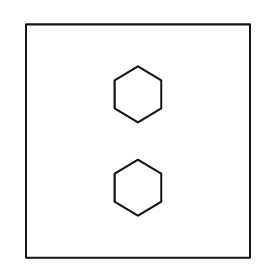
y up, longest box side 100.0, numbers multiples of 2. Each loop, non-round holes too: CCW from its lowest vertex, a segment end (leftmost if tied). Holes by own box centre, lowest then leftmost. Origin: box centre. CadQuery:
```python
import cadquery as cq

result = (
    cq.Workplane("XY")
    .moveTo(-48.0, -50.0)
    .lineTo(48.0, -50.0)
    .lineTo(48.0, 50.0)
    .lineTo(-48.0, 50.0)
    .close()
    .moveTo(0.0, -32.0)
    .lineTo(10.0, -26.0)
    .lineTo(10.0, -14.0)
    .lineTo(0.0, -8.0)
    .lineTo(-10.0, -14.0)
    .lineTo(-10.0, -26.0)
    .close()
    .moveTo(0.0, 8.0)
    .lineTo(10.0, 14.0)
    .lineTo(10.0, 26.0)
    .lineTo(0.0, 32.0)
    .lineTo(-10.0, 26.0)
    .lineTo(-10.0, 14.0)
    .close()
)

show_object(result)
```